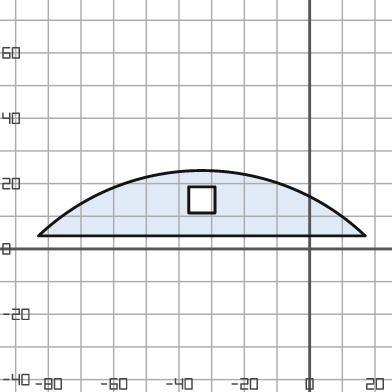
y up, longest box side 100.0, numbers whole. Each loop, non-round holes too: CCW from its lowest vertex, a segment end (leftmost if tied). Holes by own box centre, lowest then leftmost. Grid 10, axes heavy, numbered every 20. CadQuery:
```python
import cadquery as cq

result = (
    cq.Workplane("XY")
    .moveTo(-83.0, 4.0)
    .lineTo(17.0, 4.0)
    .threePointArc((-33.0, 24.0), (-83.0, 4.0))
    .close()
    .moveTo(-37.0, 11.0)
    .lineTo(-29.0, 11.0)
    .lineTo(-29.0, 19.0)
    .lineTo(-37.0, 19.0)
    .close()
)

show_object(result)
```